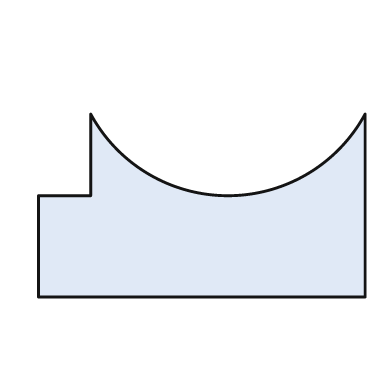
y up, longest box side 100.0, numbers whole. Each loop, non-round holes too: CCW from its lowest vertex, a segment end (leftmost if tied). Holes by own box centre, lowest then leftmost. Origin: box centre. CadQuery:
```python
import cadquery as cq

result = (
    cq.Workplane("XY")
    .moveTo(-50.0, -28.0)
    .lineTo(50.0, -28.0)
    .lineTo(50.0, 28.0)
    .threePointArc((8.0, 3.0), (-34.0, 28.0))
    .lineTo(-34.0, 3.0)
    .lineTo(-50.0, 3.0)
    .close()
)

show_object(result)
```